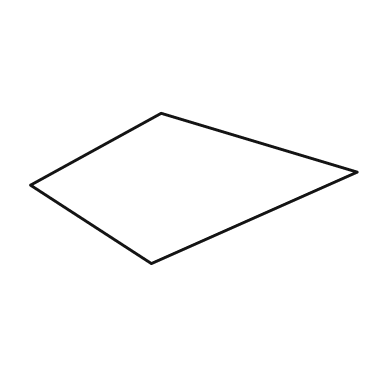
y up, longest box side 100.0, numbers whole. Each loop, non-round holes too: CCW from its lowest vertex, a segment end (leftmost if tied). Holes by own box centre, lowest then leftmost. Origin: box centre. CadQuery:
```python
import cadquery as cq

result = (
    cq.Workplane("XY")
    .moveTo(-13.0, -23.0)
    .lineTo(50.0, 5.0)
    .lineTo(-10.0, 23.0)
    .lineTo(-50.0, 1.0)
    .close()
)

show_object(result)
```